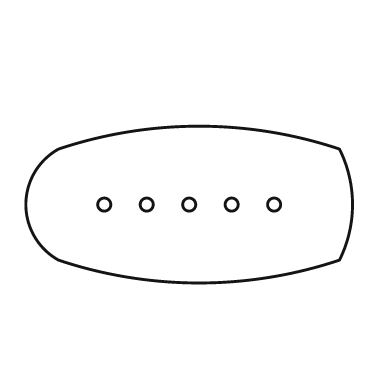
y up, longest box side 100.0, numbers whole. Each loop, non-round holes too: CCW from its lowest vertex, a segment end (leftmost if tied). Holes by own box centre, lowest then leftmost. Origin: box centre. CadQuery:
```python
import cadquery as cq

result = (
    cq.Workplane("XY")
    .moveTo(-40.0, -17.0)
    .threePointArc((3.0, -24.0), (46.0, -17.0))
    .threePointArc((50.0, 0.0), (46.0, 17.0))
    .threePointArc((3.0, 24.0), (-40.0, 17.0))
    .threePointArc((-50.0, 0.0), (-40.0, -17.0))
    .close()
    .moveTo(-26.0, 0.0)
    .circle(2.0)
    .moveTo(-13.0, 0.0)
    .circle(2.0)
    .moveTo(0.0, 0.0)
    .circle(2.0)
    .moveTo(13.0, 0.0)
    .circle(2.0)
    .moveTo(26.0, 0.0)
    .circle(2.0)
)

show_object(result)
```